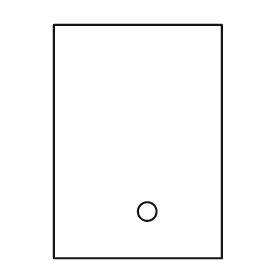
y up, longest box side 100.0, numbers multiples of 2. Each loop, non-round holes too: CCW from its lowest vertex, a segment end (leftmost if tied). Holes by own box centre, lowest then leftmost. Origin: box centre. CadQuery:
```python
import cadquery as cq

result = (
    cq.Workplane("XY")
    .moveTo(-36.0, -50.0)
    .lineTo(36.0, -50.0)
    .lineTo(36.0, 50.0)
    .lineTo(-36.0, 50.0)
    .close()
    .moveTo(4.0, -30.0)
    .circle(4.0)
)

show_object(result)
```